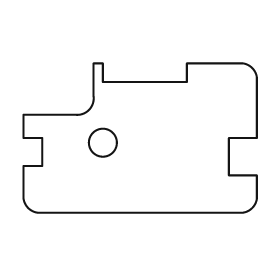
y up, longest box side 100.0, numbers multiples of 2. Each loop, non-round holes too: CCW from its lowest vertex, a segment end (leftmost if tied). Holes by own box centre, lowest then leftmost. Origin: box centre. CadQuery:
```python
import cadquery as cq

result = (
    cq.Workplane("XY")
    .moveTo(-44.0, -32.0)
    .lineTo(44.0, -32.0)
    .threePointArc((48.0, -30.0), (50.0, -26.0))
    .lineTo(50.0, -16.0)
    .lineTo(38.0, -16.0)
    .lineTo(38.0, 0.0)
    .lineTo(50.0, 0.0)
    .lineTo(50.0, 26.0)
    .threePointArc((48.0, 30.0), (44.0, 32.0))
    .lineTo(20.0, 32.0)
    .lineTo(20.0, 24.0)
    .lineTo(-16.0, 24.0)
    .lineTo(-16.0, 32.0)
    .lineTo(-20.0, 32.0)
    .lineTo(-20.0, 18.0)
    .threePointArc((-22.0, 12.0), (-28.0, 10.0))
    .lineTo(-50.0, 10.0)
    .lineTo(-50.0, 0.0)
    .lineTo(-42.0, 0.0)
    .lineTo(-42.0, -12.0)
    .lineTo(-50.0, -12.0)
    .lineTo(-50.0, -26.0)
    .threePointArc((-48.0, -30.0), (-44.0, -32.0))
    .close()
    .moveTo(-16.0, -2.0)
    .circle(6.0)
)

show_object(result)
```